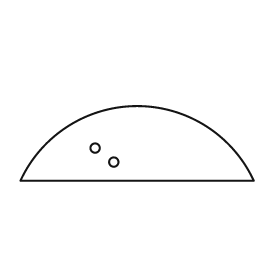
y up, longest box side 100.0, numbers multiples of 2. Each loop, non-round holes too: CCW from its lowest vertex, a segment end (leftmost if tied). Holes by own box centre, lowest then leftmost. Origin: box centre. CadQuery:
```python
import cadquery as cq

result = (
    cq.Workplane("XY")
    .moveTo(-50.0, -16.0)
    .lineTo(50.0, -16.0)
    .threePointArc((0.0, 16.0), (-50.0, -16.0))
    .close()
    .moveTo(-10.0, -8.0)
    .circle(2.0)
    .moveTo(-18.0, -2.0)
    .circle(2.0)
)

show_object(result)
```